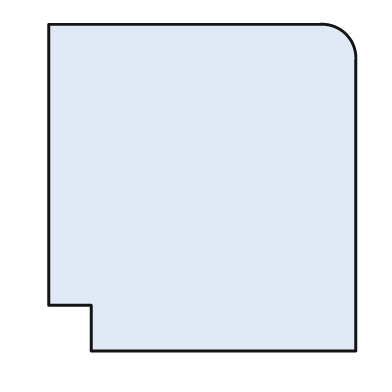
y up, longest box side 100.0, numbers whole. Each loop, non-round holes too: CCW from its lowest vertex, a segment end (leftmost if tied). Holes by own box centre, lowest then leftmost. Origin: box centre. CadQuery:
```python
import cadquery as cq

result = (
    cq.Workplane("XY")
    .moveTo(-34.0, -50.0)
    .lineTo(47.0, -50.0)
    .lineTo(47.0, 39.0)
    .threePointArc((44.0, 47.0), (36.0, 50.0))
    .lineTo(-47.0, 50.0)
    .lineTo(-47.0, -36.0)
    .lineTo(-34.0, -36.0)
    .close()
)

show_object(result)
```